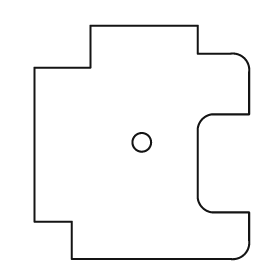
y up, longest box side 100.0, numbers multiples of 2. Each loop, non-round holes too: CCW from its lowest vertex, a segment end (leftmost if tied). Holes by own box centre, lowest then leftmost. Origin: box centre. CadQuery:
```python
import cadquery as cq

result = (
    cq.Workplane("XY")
    .moveTo(-30.0, -50.0)
    .lineTo(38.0, -50.0)
    .threePointArc((44.0, -48.0), (46.0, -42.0))
    .lineTo(46.0, -30.0)
    .lineTo(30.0, -30.0)
    .threePointArc((26.0, -28.0), (24.0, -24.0))
    .lineTo(24.0, 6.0)
    .threePointArc((26.0, 10.0), (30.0, 12.0))
    .lineTo(46.0, 12.0)
    .lineTo(46.0, 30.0)
    .threePointArc((44.0, 36.0), (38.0, 38.0))
    .lineTo(24.0, 38.0)
    .lineTo(24.0, 50.0)
    .lineTo(-22.0, 50.0)
    .lineTo(-22.0, 32.0)
    .lineTo(-46.0, 32.0)
    .lineTo(-46.0, -34.0)
    .lineTo(-30.0, -34.0)
    .close()
    .moveTo(0.0, 0.0)
    .circle(4.0)
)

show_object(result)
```